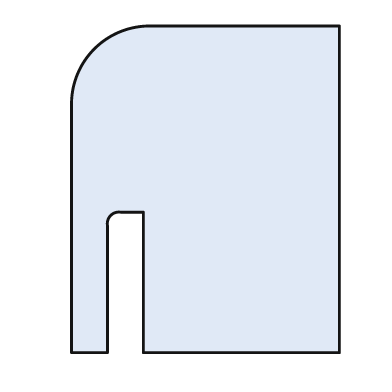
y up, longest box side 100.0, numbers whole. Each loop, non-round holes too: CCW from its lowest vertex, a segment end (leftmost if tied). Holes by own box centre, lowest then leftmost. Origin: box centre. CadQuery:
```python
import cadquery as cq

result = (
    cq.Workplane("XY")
    .moveTo(-41.0, -50.0)
    .lineTo(-30.0, -50.0)
    .lineTo(-30.0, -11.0)
    .threePointArc((-29.0, -8.0), (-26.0, -7.0))
    .lineTo(-19.0, -7.0)
    .lineTo(-19.0, -50.0)
    .lineTo(41.0, -50.0)
    .lineTo(41.0, 50.0)
    .lineTo(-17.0, 50.0)
    .threePointArc((-34.0, 43.0), (-41.0, 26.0))
    .close()
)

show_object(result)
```